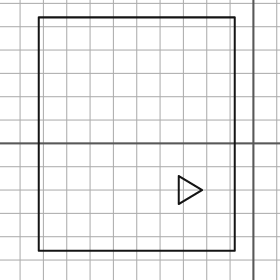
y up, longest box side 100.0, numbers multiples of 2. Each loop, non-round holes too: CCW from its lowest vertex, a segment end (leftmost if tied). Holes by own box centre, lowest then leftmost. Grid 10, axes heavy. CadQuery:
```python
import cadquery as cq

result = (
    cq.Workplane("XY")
    .moveTo(-92.0, -46.0)
    .lineTo(-8.0, -46.0)
    .lineTo(-8.0, 54.0)
    .lineTo(-92.0, 54.0)
    .close()
    .moveTo(-32.0, -26.0)
    .lineTo(-22.0, -20.0)
    .lineTo(-32.0, -14.0)
    .close()
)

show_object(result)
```